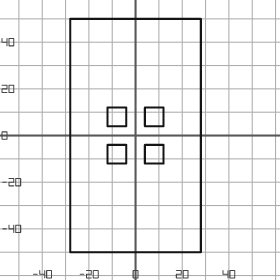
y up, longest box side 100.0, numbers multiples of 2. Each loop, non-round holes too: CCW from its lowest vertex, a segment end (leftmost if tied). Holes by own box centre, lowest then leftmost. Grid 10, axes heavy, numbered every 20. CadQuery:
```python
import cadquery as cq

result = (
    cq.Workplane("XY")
    .moveTo(-28.0, -50.0)
    .lineTo(28.0, -50.0)
    .lineTo(28.0, 50.0)
    .lineTo(-28.0, 50.0)
    .close()
    .moveTo(-12.0, -12.0)
    .lineTo(-4.0, -12.0)
    .lineTo(-4.0, -4.0)
    .lineTo(-12.0, -4.0)
    .close()
    .moveTo(4.0, -12.0)
    .lineTo(12.0, -12.0)
    .lineTo(12.0, -4.0)
    .lineTo(4.0, -4.0)
    .close()
    .moveTo(-12.0, 4.0)
    .lineTo(-4.0, 4.0)
    .lineTo(-4.0, 12.0)
    .lineTo(-12.0, 12.0)
    .close()
    .moveTo(4.0, 4.0)
    .lineTo(12.0, 4.0)
    .lineTo(12.0, 12.0)
    .lineTo(4.0, 12.0)
    .close()
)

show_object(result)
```